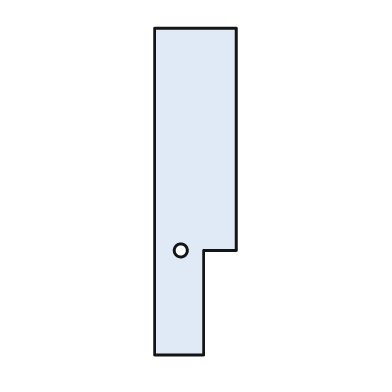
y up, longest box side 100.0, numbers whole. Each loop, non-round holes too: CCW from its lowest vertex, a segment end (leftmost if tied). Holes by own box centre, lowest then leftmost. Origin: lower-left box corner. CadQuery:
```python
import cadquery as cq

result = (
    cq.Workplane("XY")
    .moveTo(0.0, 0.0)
    .lineTo(15.0, 0.0)
    .lineTo(15.0, 32.0)
    .lineTo(25.0, 32.0)
    .lineTo(25.0, 100.0)
    .lineTo(0.0, 100.0)
    .close()
    .moveTo(8.0, 32.0)
    .circle(2.0)
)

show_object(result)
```